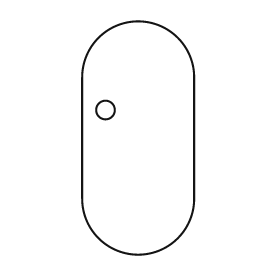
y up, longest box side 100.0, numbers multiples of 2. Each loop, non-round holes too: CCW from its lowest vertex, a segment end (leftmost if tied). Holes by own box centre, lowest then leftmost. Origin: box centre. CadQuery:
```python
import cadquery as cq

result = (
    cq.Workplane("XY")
    .moveTo(-24.0, -26.0)
    .threePointArc((0.0, -50.0), (24.0, -26.0))
    .lineTo(24.0, 26.0)
    .threePointArc((0.0, 50.0), (-24.0, 26.0))
    .close()
    .moveTo(-14.0, 12.0)
    .circle(4.0)
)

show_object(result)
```